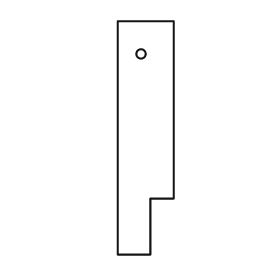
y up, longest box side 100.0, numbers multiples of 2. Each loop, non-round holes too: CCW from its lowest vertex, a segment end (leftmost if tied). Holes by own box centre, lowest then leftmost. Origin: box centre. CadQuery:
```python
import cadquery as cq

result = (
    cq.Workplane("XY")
    .moveTo(-12.0, -50.0)
    .lineTo(2.0, -50.0)
    .lineTo(2.0, -26.0)
    .lineTo(12.0, -26.0)
    .lineTo(12.0, 50.0)
    .lineTo(-12.0, 50.0)
    .close()
    .moveTo(-2.0, 36.0)
    .circle(2.0)
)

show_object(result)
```